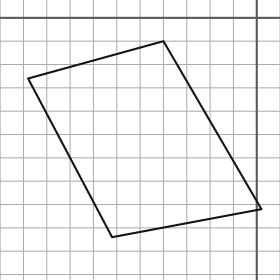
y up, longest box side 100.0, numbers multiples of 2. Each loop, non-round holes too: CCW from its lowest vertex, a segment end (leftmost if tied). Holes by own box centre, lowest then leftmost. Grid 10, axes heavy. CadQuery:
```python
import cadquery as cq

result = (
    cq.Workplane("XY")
    .moveTo(-62.0, -94.0)
    .lineTo(2.0, -82.0)
    .lineTo(-40.0, -10.0)
    .lineTo(-98.0, -26.0)
    .close()
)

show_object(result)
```